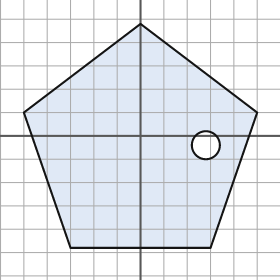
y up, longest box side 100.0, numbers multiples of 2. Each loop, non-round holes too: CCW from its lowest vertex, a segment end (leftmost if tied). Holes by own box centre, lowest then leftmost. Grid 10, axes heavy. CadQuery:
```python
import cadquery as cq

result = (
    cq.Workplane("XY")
    .moveTo(-30.0, -48.0)
    .lineTo(30.0, -48.0)
    .lineTo(50.0, 10.0)
    .lineTo(0.0, 48.0)
    .lineTo(-50.0, 10.0)
    .close()
    .moveTo(28.0, -4.0)
    .circle(6.0)
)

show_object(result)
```